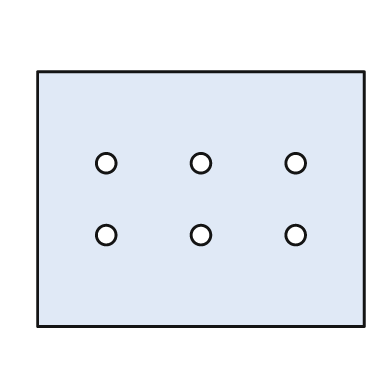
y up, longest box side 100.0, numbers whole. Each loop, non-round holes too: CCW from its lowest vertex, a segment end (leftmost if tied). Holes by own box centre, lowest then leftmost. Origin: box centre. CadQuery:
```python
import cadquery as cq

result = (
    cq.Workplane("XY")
    .moveTo(-50.0, -39.0)
    .lineTo(50.0, -39.0)
    .lineTo(50.0, 39.0)
    .lineTo(-50.0, 39.0)
    .close()
    .moveTo(-29.0, -11.0)
    .circle(3.0)
    .moveTo(0.0, -11.0)
    .circle(3.0)
    .moveTo(29.0, -11.0)
    .circle(3.0)
    .moveTo(-29.0, 11.0)
    .circle(3.0)
    .moveTo(0.0, 11.0)
    .circle(3.0)
    .moveTo(29.0, 11.0)
    .circle(3.0)
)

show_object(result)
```